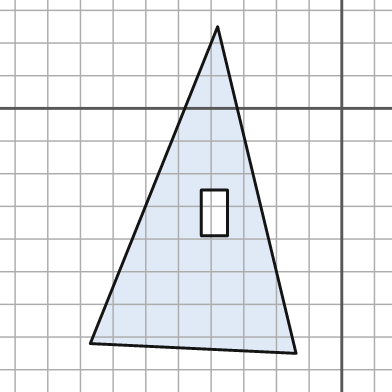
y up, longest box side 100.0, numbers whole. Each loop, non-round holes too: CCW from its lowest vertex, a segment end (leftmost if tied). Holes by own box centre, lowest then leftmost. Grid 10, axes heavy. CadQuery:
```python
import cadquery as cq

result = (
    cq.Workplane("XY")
    .moveTo(-14.0, -75.0)
    .lineTo(-38.0, 25.0)
    .lineTo(-77.0, -72.0)
    .close()
    .moveTo(-43.0, -39.0)
    .lineTo(-35.0, -39.0)
    .lineTo(-35.0, -25.0)
    .lineTo(-43.0, -25.0)
    .close()
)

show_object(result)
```